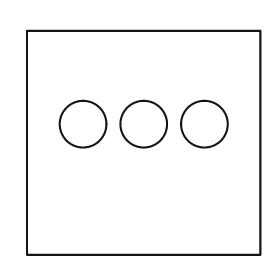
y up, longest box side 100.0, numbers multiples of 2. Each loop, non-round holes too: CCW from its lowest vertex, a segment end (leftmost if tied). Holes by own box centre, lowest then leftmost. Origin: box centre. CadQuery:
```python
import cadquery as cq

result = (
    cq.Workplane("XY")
    .moveTo(-50.0, -48.0)
    .lineTo(50.0, -48.0)
    .lineTo(50.0, 48.0)
    .lineTo(-50.0, 48.0)
    .close()
    .moveTo(-26.0, 8.0)
    .circle(10.0)
    .moveTo(0.0, 8.0)
    .circle(10.0)
    .moveTo(26.0, 8.0)
    .circle(10.0)
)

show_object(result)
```